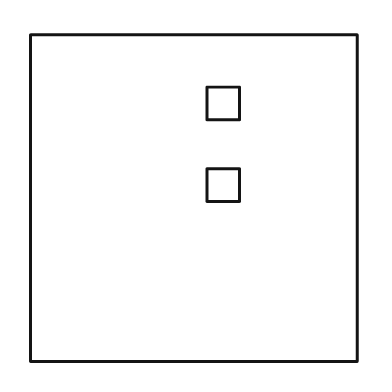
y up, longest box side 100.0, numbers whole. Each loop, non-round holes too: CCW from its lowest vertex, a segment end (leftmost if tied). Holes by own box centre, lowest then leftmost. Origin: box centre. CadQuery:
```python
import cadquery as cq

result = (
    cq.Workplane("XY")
    .moveTo(-50.0, -50.0)
    .lineTo(50.0, -50.0)
    .lineTo(50.0, 50.0)
    .lineTo(-50.0, 50.0)
    .close()
    .moveTo(4.0, -1.0)
    .lineTo(14.0, -1.0)
    .lineTo(14.0, 9.0)
    .lineTo(4.0, 9.0)
    .close()
    .moveTo(4.0, 24.0)
    .lineTo(14.0, 24.0)
    .lineTo(14.0, 34.0)
    .lineTo(4.0, 34.0)
    .close()
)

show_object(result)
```